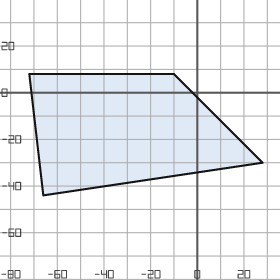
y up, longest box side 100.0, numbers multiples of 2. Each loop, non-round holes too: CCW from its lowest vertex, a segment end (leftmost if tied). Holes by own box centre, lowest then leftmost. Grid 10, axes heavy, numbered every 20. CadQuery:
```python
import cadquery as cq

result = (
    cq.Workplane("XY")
    .moveTo(-66.0, -44.0)
    .lineTo(28.0, -30.0)
    .lineTo(-10.0, 8.0)
    .lineTo(-72.0, 8.0)
    .close()
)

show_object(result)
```